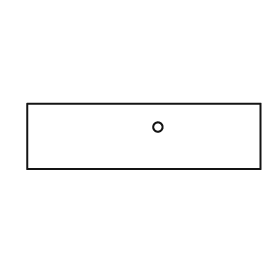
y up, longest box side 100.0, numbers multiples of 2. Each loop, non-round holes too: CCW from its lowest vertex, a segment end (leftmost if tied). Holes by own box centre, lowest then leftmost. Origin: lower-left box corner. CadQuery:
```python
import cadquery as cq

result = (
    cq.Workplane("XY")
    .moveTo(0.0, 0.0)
    .lineTo(100.0, 0.0)
    .lineTo(100.0, 28.0)
    .lineTo(0.0, 28.0)
    .close()
    .moveTo(56.0, 18.0)
    .circle(2.0)
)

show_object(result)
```